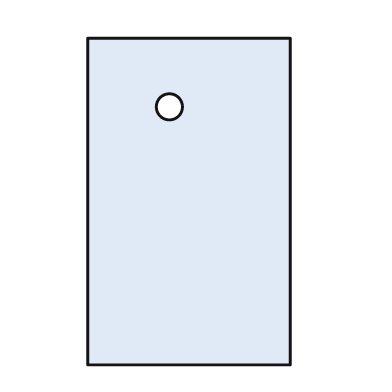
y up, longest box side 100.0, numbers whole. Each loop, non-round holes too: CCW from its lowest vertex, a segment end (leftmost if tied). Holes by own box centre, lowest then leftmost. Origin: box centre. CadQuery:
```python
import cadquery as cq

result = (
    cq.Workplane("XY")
    .moveTo(-31.0, -50.0)
    .lineTo(31.0, -50.0)
    .lineTo(31.0, 50.0)
    .lineTo(-31.0, 50.0)
    .close()
    .moveTo(-6.0, 29.0)
    .circle(4.0)
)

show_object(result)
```